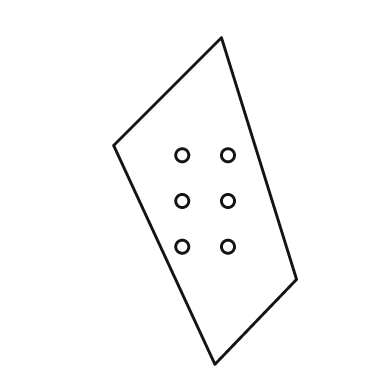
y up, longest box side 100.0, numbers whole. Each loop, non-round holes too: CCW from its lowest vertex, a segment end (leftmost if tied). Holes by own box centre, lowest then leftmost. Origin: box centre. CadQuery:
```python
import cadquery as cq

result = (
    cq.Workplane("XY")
    .moveTo(3.0, -50.0)
    .lineTo(28.0, -24.0)
    .lineTo(5.0, 50.0)
    .lineTo(-28.0, 17.0)
    .close()
    .moveTo(-7.0, -14.0)
    .circle(2.0)
    .moveTo(7.0, -14.0)
    .circle(2.0)
    .moveTo(-7.0, 0.0)
    .circle(2.0)
    .moveTo(7.0, 0.0)
    .circle(2.0)
    .moveTo(-7.0, 14.0)
    .circle(2.0)
    .moveTo(7.0, 14.0)
    .circle(2.0)
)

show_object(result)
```